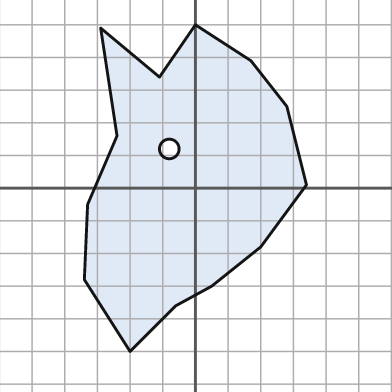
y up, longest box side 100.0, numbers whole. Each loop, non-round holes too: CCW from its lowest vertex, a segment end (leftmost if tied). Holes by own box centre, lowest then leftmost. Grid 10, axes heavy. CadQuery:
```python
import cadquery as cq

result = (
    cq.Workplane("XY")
    .moveTo(-20.0, -50.0)
    .lineTo(-6.0, -36.0)
    .lineTo(5.0, -30.0)
    .lineTo(20.0, -18.0)
    .lineTo(34.0, 1.0)
    .lineTo(28.0, 25.0)
    .lineTo(17.0, 39.0)
    .lineTo(0.0, 50.0)
    .lineTo(-11.0, 34.0)
    .lineTo(-29.0, 49.0)
    .lineTo(-24.0, 16.0)
    .lineTo(-33.0, -5.0)
    .lineTo(-34.0, -28.0)
    .close()
    .moveTo(-8.0, 12.0)
    .circle(3.0)
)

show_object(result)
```